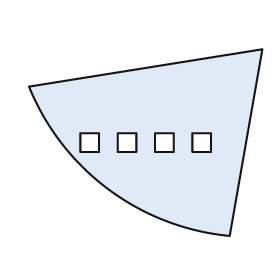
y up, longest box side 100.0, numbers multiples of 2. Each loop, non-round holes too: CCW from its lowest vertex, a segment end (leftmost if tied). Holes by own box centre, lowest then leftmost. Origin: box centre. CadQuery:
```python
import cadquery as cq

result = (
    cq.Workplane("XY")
    .moveTo(36.0, -40.0)
    .lineTo(50.0, 40.0)
    .lineTo(-50.0, 24.0)
    .threePointArc((-16.0, -20.0), (36.0, -40.0))
    .close()
    .moveTo(-28.0, -4.0)
    .lineTo(-20.0, -4.0)
    .lineTo(-20.0, 4.0)
    .lineTo(-28.0, 4.0)
    .close()
    .moveTo(-12.0, -4.0)
    .lineTo(-4.0, -4.0)
    .lineTo(-4.0, 4.0)
    .lineTo(-12.0, 4.0)
    .close()
    .moveTo(4.0, -4.0)
    .lineTo(12.0, -4.0)
    .lineTo(12.0, 4.0)
    .lineTo(4.0, 4.0)
    .close()
    .moveTo(20.0, -4.0)
    .lineTo(28.0, -4.0)
    .lineTo(28.0, 4.0)
    .lineTo(20.0, 4.0)
    .close()
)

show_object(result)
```